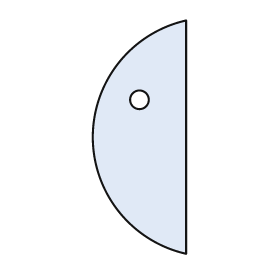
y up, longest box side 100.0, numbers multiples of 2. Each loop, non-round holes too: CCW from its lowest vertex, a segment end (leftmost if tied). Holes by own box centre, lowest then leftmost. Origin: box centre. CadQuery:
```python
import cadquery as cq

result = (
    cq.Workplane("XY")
    .moveTo(20.0, -50.0)
    .lineTo(20.0, 50.0)
    .threePointArc((-20.0, 0.0), (20.0, -50.0))
    .close()
    .moveTo(0.0, 16.0)
    .circle(4.0)
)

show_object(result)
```